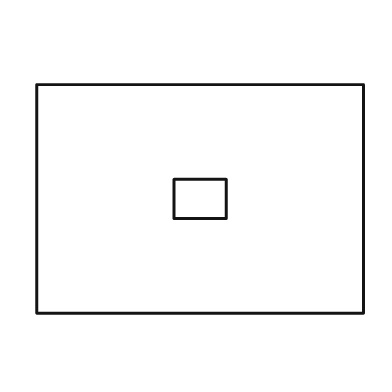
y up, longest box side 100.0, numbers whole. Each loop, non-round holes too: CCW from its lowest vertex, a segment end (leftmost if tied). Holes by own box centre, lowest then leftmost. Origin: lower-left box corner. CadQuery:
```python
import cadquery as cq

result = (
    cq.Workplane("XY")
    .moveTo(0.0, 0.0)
    .lineTo(100.0, 0.0)
    .lineTo(100.0, 70.0)
    .lineTo(0.0, 70.0)
    .close()
    .moveTo(42.0, 29.0)
    .lineTo(58.0, 29.0)
    .lineTo(58.0, 41.0)
    .lineTo(42.0, 41.0)
    .close()
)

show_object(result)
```